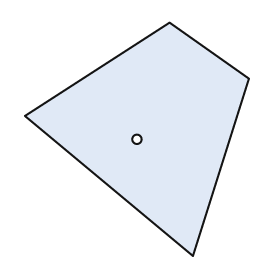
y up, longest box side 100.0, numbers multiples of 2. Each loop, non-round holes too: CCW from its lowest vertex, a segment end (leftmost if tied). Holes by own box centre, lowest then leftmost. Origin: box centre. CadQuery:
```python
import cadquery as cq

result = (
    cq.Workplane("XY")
    .moveTo(24.0, -50.0)
    .lineTo(48.0, 26.0)
    .lineTo(14.0, 50.0)
    .lineTo(-48.0, 10.0)
    .close()
    .moveTo(0.0, 0.0)
    .circle(2.0)
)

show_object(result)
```